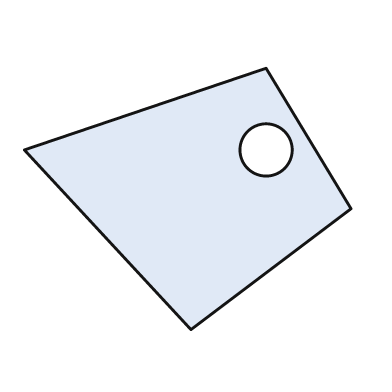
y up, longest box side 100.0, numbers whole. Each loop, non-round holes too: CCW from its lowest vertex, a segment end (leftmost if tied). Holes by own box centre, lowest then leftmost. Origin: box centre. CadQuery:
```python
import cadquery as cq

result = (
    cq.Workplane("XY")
    .moveTo(1.0, -40.0)
    .lineTo(50.0, -3.0)
    .lineTo(24.0, 40.0)
    .lineTo(-50.0, 15.0)
    .close()
    .moveTo(24.0, 15.0)
    .circle(8.0)
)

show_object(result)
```